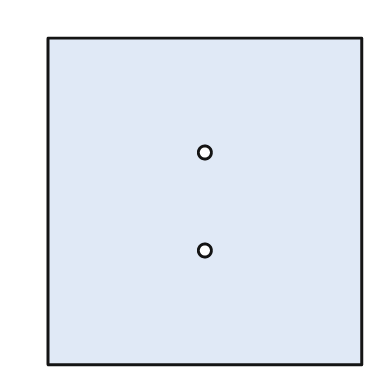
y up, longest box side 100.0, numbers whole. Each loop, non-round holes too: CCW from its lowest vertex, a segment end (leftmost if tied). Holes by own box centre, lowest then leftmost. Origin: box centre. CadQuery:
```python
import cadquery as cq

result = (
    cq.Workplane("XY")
    .moveTo(-48.0, -50.0)
    .lineTo(48.0, -50.0)
    .lineTo(48.0, 50.0)
    .lineTo(-48.0, 50.0)
    .close()
    .moveTo(0.0, -15.0)
    .circle(2.0)
    .moveTo(0.0, 15.0)
    .circle(2.0)
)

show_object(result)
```